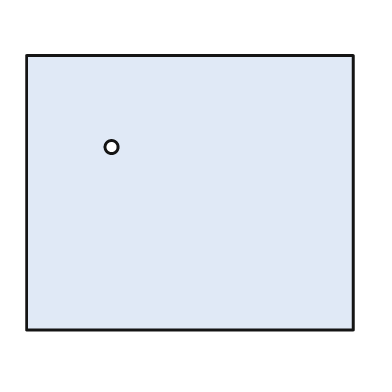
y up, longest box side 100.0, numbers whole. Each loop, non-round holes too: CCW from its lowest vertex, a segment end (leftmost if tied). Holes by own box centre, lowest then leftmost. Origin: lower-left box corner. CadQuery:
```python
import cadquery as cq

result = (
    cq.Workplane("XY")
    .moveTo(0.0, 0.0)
    .lineTo(100.0, 0.0)
    .lineTo(100.0, 84.0)
    .lineTo(0.0, 84.0)
    .close()
    .moveTo(26.0, 56.0)
    .circle(2.0)
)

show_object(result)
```